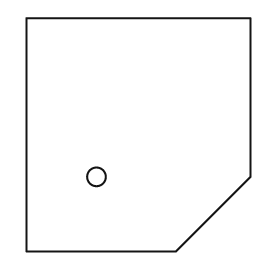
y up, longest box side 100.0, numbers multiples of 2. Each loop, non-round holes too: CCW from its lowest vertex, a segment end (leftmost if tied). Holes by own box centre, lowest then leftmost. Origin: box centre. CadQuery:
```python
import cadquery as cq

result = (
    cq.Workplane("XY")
    .moveTo(-48.0, -50.0)
    .lineTo(16.0, -50.0)
    .lineTo(48.0, -18.0)
    .lineTo(48.0, 50.0)
    .lineTo(-48.0, 50.0)
    .close()
    .moveTo(-18.0, -18.0)
    .circle(4.0)
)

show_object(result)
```